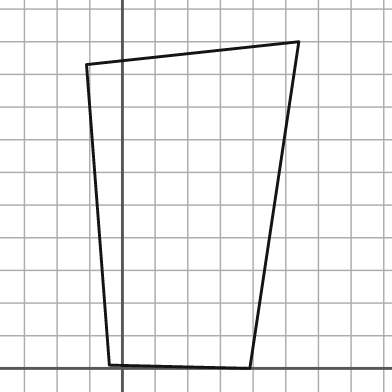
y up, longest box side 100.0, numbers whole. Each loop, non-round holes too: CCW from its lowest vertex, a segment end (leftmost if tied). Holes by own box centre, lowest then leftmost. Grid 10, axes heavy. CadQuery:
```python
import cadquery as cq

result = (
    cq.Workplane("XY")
    .moveTo(39.0, 0.0)
    .lineTo(54.0, 100.0)
    .lineTo(-11.0, 93.0)
    .lineTo(-4.0, 1.0)
    .close()
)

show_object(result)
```